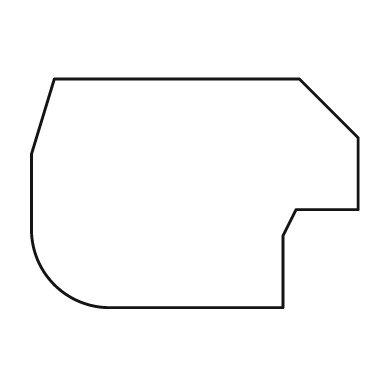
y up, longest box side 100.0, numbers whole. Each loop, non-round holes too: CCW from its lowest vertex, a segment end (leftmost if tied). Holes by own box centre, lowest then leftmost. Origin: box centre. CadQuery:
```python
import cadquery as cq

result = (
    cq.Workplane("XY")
    .moveTo(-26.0, -35.0)
    .lineTo(27.0, -35.0)
    .lineTo(27.0, -13.0)
    .lineTo(31.0, -5.0)
    .lineTo(50.0, -5.0)
    .lineTo(50.0, 17.0)
    .lineTo(32.0, 35.0)
    .lineTo(-43.0, 35.0)
    .lineTo(-50.0, 12.0)
    .lineTo(-50.0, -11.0)
    .threePointArc((-43.0, -28.0), (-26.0, -35.0))
    .close()
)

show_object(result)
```